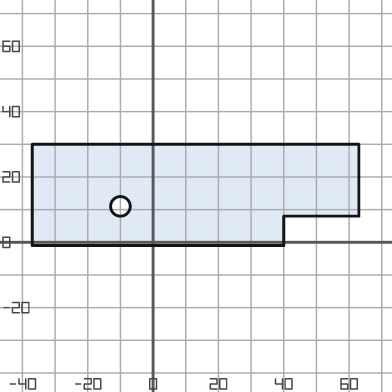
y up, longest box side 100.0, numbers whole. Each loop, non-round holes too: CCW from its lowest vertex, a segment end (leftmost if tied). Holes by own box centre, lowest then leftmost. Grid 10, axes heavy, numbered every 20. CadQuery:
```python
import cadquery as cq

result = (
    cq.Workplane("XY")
    .moveTo(-37.0, -1.0)
    .lineTo(40.0, -1.0)
    .lineTo(40.0, 8.0)
    .lineTo(63.0, 8.0)
    .lineTo(63.0, 30.0)
    .lineTo(-37.0, 30.0)
    .close()
    .moveTo(-10.0, 11.0)
    .circle(3.0)
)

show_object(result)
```